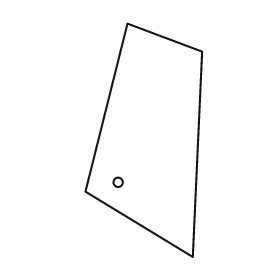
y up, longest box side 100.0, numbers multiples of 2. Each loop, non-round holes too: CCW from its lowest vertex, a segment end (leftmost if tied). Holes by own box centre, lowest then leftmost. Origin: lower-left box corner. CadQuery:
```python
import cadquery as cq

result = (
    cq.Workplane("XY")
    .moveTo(46.0, 0.0)
    .lineTo(50.0, 88.0)
    .lineTo(18.0, 100.0)
    .lineTo(0.0, 28.0)
    .close()
    .moveTo(14.0, 32.0)
    .circle(2.0)
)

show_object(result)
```